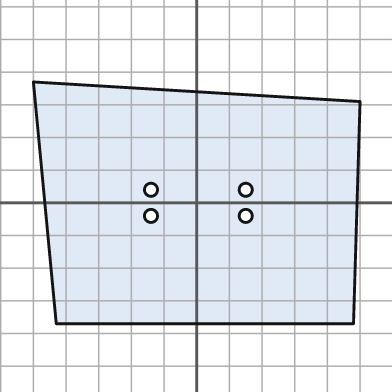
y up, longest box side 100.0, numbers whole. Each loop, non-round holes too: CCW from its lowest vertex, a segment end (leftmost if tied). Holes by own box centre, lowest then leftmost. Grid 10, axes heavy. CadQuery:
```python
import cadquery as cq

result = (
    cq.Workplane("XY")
    .moveTo(-43.0, -37.0)
    .lineTo(48.0, -37.0)
    .lineTo(50.0, 31.0)
    .lineTo(-50.0, 37.0)
    .close()
    .moveTo(-14.0, -4.0)
    .circle(2.0)
    .moveTo(15.0, -4.0)
    .circle(2.0)
    .moveTo(-14.0, 4.0)
    .circle(2.0)
    .moveTo(15.0, 4.0)
    .circle(2.0)
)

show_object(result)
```